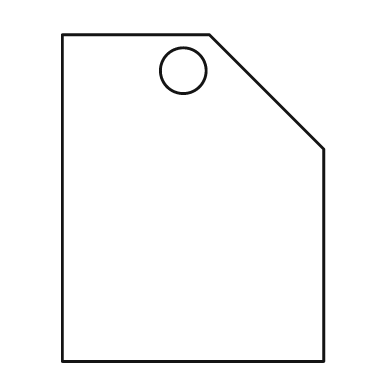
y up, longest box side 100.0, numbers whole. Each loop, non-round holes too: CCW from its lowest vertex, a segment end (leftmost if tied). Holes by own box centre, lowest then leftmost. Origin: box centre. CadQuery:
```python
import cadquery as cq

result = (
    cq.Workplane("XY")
    .moveTo(-40.0, -50.0)
    .lineTo(40.0, -50.0)
    .lineTo(40.0, 15.0)
    .lineTo(5.0, 50.0)
    .lineTo(-40.0, 50.0)
    .close()
    .moveTo(-3.0, 39.0)
    .circle(7.0)
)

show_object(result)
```